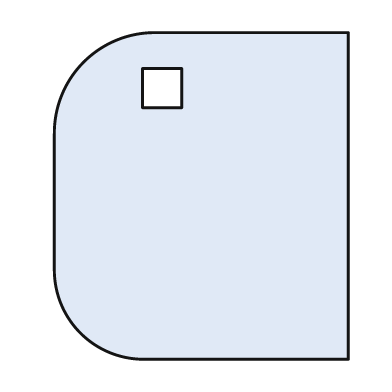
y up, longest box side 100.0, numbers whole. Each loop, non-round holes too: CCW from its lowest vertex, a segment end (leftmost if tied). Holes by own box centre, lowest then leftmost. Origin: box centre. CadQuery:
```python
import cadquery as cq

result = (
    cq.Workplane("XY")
    .moveTo(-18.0, -50.0)
    .lineTo(45.0, -50.0)
    .lineTo(45.0, 50.0)
    .lineTo(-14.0, 50.0)
    .threePointArc((-36.0, 41.0), (-45.0, 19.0))
    .lineTo(-45.0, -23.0)
    .threePointArc((-37.0, -42.0), (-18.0, -50.0))
    .close()
    .moveTo(-18.0, 27.0)
    .lineTo(-6.0, 27.0)
    .lineTo(-6.0, 39.0)
    .lineTo(-18.0, 39.0)
    .close()
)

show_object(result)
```